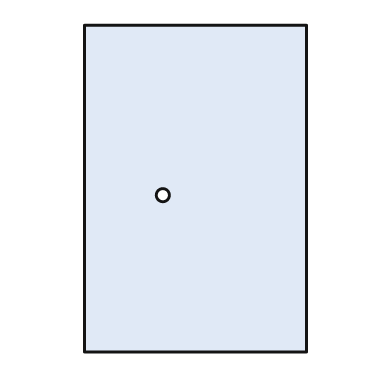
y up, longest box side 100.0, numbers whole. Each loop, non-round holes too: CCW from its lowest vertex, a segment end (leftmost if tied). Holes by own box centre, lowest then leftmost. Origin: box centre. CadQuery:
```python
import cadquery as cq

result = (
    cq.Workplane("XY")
    .moveTo(-34.0, -50.0)
    .lineTo(34.0, -50.0)
    .lineTo(34.0, 50.0)
    .lineTo(-34.0, 50.0)
    .close()
    .moveTo(-10.0, -2.0)
    .circle(2.0)
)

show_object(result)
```